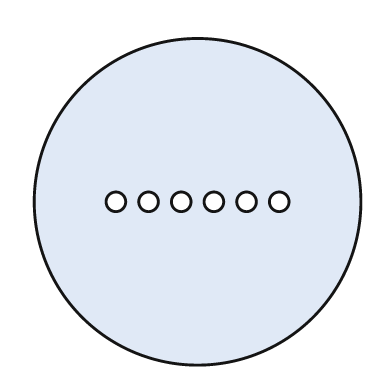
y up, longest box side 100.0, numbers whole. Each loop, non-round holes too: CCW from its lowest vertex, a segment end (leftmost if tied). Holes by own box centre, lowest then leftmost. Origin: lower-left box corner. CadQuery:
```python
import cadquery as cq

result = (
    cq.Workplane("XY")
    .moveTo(50.0, 50.0)
    .circle(50.0)
    .moveTo(25.0, 50.0)
    .circle(3.0)
    .moveTo(35.0, 50.0)
    .circle(3.0)
    .moveTo(45.0, 50.0)
    .circle(3.0)
    .moveTo(55.0, 50.0)
    .circle(3.0)
    .moveTo(65.0, 50.0)
    .circle(3.0)
    .moveTo(75.0, 50.0)
    .circle(3.0)
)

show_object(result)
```